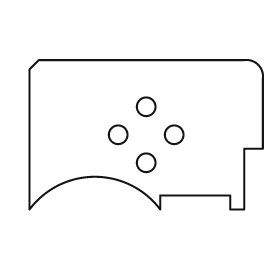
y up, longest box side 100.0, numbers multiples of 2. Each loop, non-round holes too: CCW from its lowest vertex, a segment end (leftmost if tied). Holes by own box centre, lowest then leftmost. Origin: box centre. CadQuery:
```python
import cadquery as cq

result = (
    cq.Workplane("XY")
    .moveTo(-50.0, -32.0)
    .threePointArc((-22.0, -18.0), (6.0, -32.0))
    .lineTo(6.0, -26.0)
    .lineTo(36.0, -26.0)
    .lineTo(36.0, -32.0)
    .lineTo(42.0, -32.0)
    .lineTo(42.0, -6.0)
    .lineTo(50.0, -6.0)
    .lineTo(50.0, 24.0)
    .threePointArc((48.0, 30.0), (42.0, 32.0))
    .lineTo(-46.0, 32.0)
    .lineTo(-50.0, 28.0)
    .close()
    .moveTo(0.0, -12.0)
    .circle(4.0)
    .moveTo(-12.0, 0.0)
    .circle(4.0)
    .moveTo(12.0, 0.0)
    .circle(4.0)
    .moveTo(0.0, 12.0)
    .circle(4.0)
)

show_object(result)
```